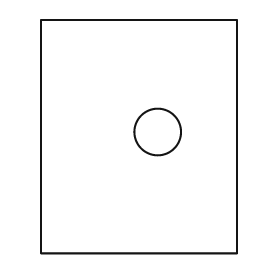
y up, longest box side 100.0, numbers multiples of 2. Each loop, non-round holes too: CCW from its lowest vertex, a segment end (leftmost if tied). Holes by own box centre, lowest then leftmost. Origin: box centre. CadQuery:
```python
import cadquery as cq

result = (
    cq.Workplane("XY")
    .moveTo(-42.0, -50.0)
    .lineTo(42.0, -50.0)
    .lineTo(42.0, 50.0)
    .lineTo(-42.0, 50.0)
    .close()
    .moveTo(8.0, 2.0)
    .circle(10.0)
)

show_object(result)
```